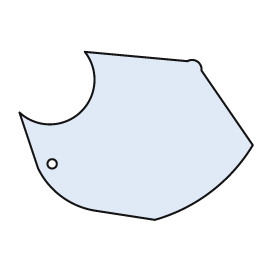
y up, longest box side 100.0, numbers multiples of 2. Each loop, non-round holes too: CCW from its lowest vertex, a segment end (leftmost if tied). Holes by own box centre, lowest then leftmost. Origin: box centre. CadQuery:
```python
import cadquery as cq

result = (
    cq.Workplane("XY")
    .moveTo(8.0, -36.0)
    .threePointArc((32.0, -24.0), (50.0, -4.0))
    .lineTo(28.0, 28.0)
    .threePointArc((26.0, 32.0), (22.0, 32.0))
    .lineTo(-22.0, 36.0)
    .threePointArc((-24.0, 10.0), (-50.0, 10.0))
    .lineTo(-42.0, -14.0)
    .threePointArc((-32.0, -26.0), (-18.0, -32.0))
    .close()
    .moveTo(-36.0, -12.0)
    .circle(2.0)
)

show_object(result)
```